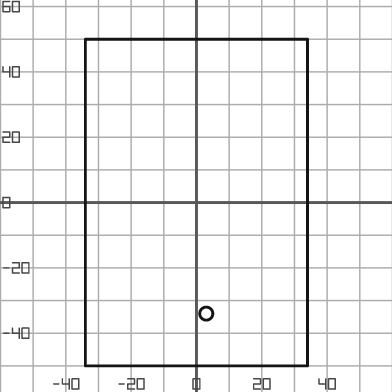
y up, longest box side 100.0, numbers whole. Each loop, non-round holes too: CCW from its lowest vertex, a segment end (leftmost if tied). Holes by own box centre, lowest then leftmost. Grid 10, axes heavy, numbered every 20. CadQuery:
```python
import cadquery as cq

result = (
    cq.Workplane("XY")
    .moveTo(-34.0, -50.0)
    .lineTo(34.0, -50.0)
    .lineTo(34.0, 50.0)
    .lineTo(-34.0, 50.0)
    .close()
    .moveTo(3.0, -34.0)
    .circle(2.0)
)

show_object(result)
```